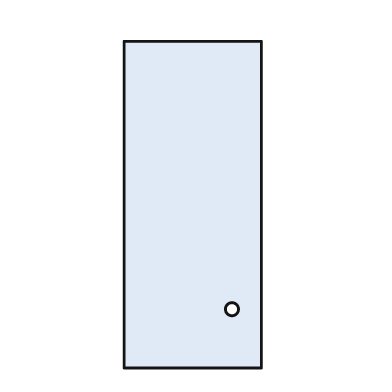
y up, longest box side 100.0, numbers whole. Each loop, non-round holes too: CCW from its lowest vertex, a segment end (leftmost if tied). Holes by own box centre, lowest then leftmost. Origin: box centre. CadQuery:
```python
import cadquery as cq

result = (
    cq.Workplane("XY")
    .moveTo(-21.0, -50.0)
    .lineTo(21.0, -50.0)
    .lineTo(21.0, 50.0)
    .lineTo(-21.0, 50.0)
    .close()
    .moveTo(12.0, -32.0)
    .circle(2.0)
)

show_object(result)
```